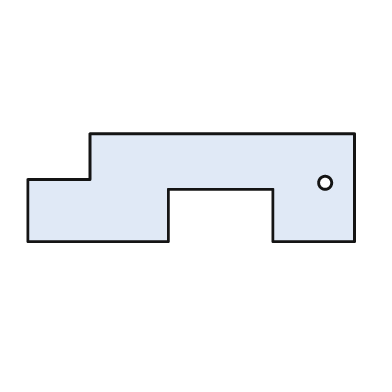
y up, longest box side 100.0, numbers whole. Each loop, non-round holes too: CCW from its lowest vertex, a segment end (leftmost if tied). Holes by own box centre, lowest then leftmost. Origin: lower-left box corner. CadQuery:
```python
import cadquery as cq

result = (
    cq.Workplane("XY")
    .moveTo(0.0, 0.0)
    .lineTo(43.0, 0.0)
    .lineTo(43.0, 16.0)
    .lineTo(75.0, 16.0)
    .lineTo(75.0, 0.0)
    .lineTo(100.0, 0.0)
    .lineTo(100.0, 33.0)
    .lineTo(19.0, 33.0)
    .lineTo(19.0, 19.0)
    .lineTo(0.0, 19.0)
    .close()
    .moveTo(91.0, 18.0)
    .circle(2.0)
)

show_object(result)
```